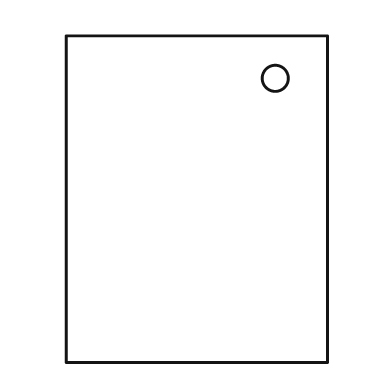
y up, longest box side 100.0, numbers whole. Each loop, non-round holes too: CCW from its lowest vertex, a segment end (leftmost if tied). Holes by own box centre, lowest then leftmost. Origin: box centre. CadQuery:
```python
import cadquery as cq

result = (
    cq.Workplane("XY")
    .moveTo(-40.0, -50.0)
    .lineTo(40.0, -50.0)
    .lineTo(40.0, 50.0)
    .lineTo(-40.0, 50.0)
    .close()
    .moveTo(24.0, 37.0)
    .circle(4.0)
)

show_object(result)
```